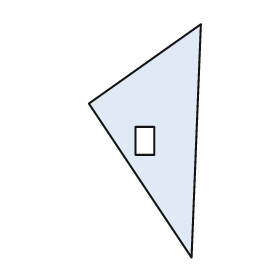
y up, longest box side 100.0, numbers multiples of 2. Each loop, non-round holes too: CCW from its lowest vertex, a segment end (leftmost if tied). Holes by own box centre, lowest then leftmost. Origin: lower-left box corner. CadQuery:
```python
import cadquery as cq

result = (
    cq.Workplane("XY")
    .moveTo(44.0, 0.0)
    .lineTo(48.0, 100.0)
    .lineTo(0.0, 66.0)
    .close()
    .moveTo(20.0, 44.0)
    .lineTo(28.0, 44.0)
    .lineTo(28.0, 56.0)
    .lineTo(20.0, 56.0)
    .close()
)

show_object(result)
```